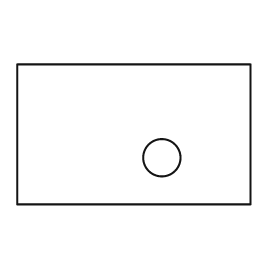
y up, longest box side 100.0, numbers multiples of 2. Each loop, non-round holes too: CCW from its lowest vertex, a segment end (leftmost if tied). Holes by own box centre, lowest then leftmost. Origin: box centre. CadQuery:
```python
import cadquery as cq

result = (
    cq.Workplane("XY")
    .moveTo(-50.0, -30.0)
    .lineTo(50.0, -30.0)
    .lineTo(50.0, 30.0)
    .lineTo(-50.0, 30.0)
    .close()
    .moveTo(12.0, -10.0)
    .circle(8.0)
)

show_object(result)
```